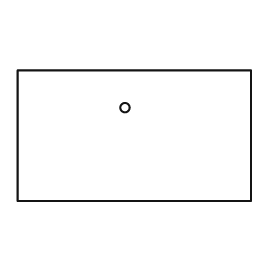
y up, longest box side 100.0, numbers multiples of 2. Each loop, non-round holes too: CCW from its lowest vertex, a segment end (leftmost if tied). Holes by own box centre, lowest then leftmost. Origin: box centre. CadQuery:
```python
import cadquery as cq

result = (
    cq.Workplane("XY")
    .moveTo(-50.0, -28.0)
    .lineTo(50.0, -28.0)
    .lineTo(50.0, 28.0)
    .lineTo(-50.0, 28.0)
    .close()
    .moveTo(-4.0, 12.0)
    .circle(2.0)
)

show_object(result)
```